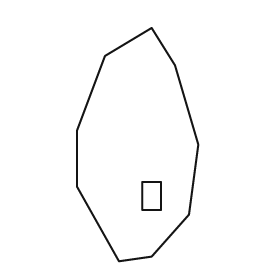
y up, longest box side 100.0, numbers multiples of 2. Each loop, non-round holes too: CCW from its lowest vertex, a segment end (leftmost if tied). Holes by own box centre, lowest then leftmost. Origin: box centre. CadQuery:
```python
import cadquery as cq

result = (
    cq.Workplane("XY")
    .moveTo(-8.0, -50.0)
    .lineTo(6.0, -48.0)
    .lineTo(22.0, -30.0)
    .lineTo(26.0, 0.0)
    .lineTo(16.0, 34.0)
    .lineTo(6.0, 50.0)
    .lineTo(-14.0, 38.0)
    .lineTo(-26.0, 6.0)
    .lineTo(-26.0, -18.0)
    .close()
    .moveTo(2.0, -28.0)
    .lineTo(10.0, -28.0)
    .lineTo(10.0, -16.0)
    .lineTo(2.0, -16.0)
    .close()
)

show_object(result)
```